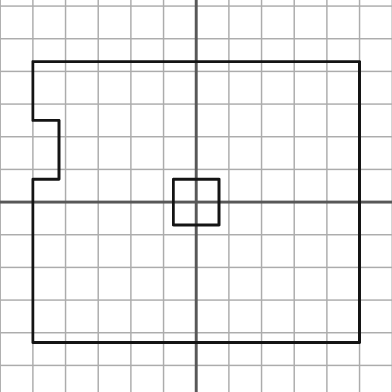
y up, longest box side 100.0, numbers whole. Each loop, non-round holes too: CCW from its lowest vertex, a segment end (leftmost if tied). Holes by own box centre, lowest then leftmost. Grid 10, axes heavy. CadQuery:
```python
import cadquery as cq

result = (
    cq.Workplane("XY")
    .moveTo(-50.0, -43.0)
    .lineTo(50.0, -43.0)
    .lineTo(50.0, 43.0)
    .lineTo(-50.0, 43.0)
    .lineTo(-50.0, 25.0)
    .lineTo(-42.0, 25.0)
    .lineTo(-42.0, 7.0)
    .lineTo(-50.0, 7.0)
    .close()
    .moveTo(-7.0, -7.0)
    .lineTo(7.0, -7.0)
    .lineTo(7.0, 7.0)
    .lineTo(-7.0, 7.0)
    .close()
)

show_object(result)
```